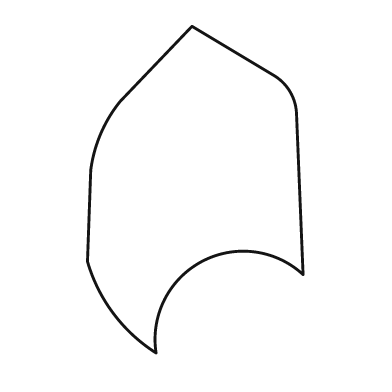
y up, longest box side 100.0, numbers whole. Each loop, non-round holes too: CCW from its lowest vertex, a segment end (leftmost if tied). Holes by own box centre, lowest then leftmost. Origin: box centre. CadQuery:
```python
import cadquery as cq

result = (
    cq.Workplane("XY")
    .moveTo(-12.0, -50.0)
    .threePointArc((2.0, -22.0), (33.0, -26.0))
    .lineTo(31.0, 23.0)
    .threePointArc((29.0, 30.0), (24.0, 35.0))
    .lineTo(-1.0, 50.0)
    .lineTo(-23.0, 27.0)
    .threePointArc((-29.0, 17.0), (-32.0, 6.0))
    .lineTo(-33.0, -22.0)
    .threePointArc((-25.0, -38.0), (-12.0, -50.0))
    .close()
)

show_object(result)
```